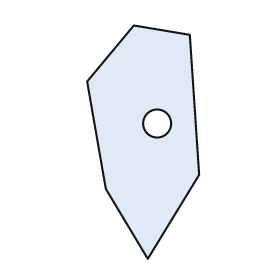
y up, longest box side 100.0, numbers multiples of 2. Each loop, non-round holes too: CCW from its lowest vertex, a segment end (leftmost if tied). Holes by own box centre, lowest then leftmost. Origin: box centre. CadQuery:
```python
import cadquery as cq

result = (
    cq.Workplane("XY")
    .moveTo(2.0, -50.0)
    .lineTo(24.0, -14.0)
    .lineTo(20.0, 46.0)
    .lineTo(-4.0, 50.0)
    .lineTo(-24.0, 26.0)
    .lineTo(-16.0, -20.0)
    .close()
    .moveTo(6.0, 8.0)
    .circle(6.0)
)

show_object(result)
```